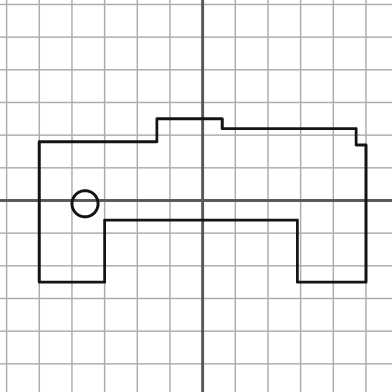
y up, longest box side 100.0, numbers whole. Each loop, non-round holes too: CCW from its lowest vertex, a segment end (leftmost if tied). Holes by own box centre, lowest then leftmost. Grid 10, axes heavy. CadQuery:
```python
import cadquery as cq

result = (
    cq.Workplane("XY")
    .moveTo(-50.0, -25.0)
    .lineTo(-30.0, -25.0)
    .lineTo(-30.0, -6.0)
    .lineTo(29.0, -6.0)
    .lineTo(29.0, -25.0)
    .lineTo(50.0, -25.0)
    .lineTo(50.0, 17.0)
    .lineTo(47.0, 17.0)
    .lineTo(47.0, 22.0)
    .lineTo(6.0, 22.0)
    .lineTo(6.0, 25.0)
    .lineTo(-14.0, 25.0)
    .lineTo(-14.0, 18.0)
    .lineTo(-50.0, 18.0)
    .close()
    .moveTo(-36.0, -1.0)
    .circle(4.0)
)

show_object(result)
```